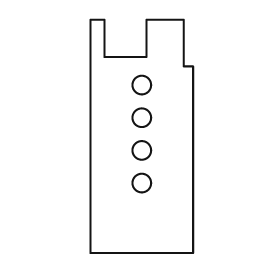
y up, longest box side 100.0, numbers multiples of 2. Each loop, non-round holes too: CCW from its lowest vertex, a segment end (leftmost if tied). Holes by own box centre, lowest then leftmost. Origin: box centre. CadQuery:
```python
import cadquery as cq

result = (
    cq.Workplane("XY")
    .moveTo(-22.0, -50.0)
    .lineTo(22.0, -50.0)
    .lineTo(22.0, 30.0)
    .lineTo(18.0, 30.0)
    .lineTo(18.0, 50.0)
    .lineTo(2.0, 50.0)
    .lineTo(2.0, 34.0)
    .lineTo(-16.0, 34.0)
    .lineTo(-16.0, 50.0)
    .lineTo(-22.0, 50.0)
    .close()
    .moveTo(0.0, -20.0)
    .circle(4.0)
    .moveTo(0.0, -6.0)
    .circle(4.0)
    .moveTo(0.0, 8.0)
    .circle(4.0)
    .moveTo(0.0, 22.0)
    .circle(4.0)
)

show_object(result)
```